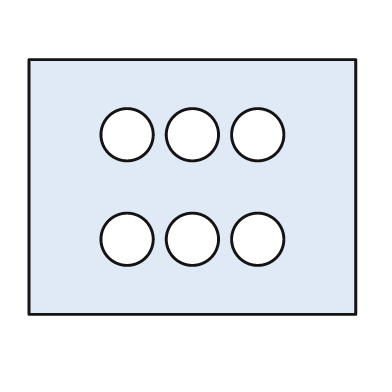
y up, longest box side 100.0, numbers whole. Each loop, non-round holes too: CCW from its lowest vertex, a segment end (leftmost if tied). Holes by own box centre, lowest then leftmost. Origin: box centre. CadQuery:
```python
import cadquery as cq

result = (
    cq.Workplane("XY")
    .moveTo(-50.0, -39.0)
    .lineTo(50.0, -39.0)
    .lineTo(50.0, 39.0)
    .lineTo(-50.0, 39.0)
    .close()
    .moveTo(-20.0, -16.0)
    .circle(8.0)
    .moveTo(0.0, -16.0)
    .circle(8.0)
    .moveTo(20.0, -16.0)
    .circle(8.0)
    .moveTo(-20.0, 16.0)
    .circle(8.0)
    .moveTo(0.0, 16.0)
    .circle(8.0)
    .moveTo(20.0, 16.0)
    .circle(8.0)
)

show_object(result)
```